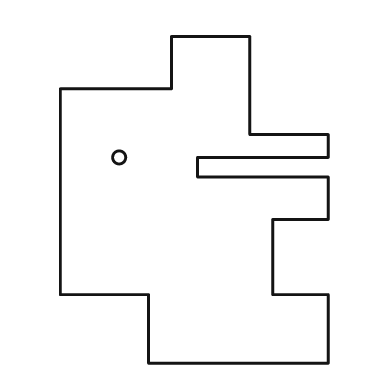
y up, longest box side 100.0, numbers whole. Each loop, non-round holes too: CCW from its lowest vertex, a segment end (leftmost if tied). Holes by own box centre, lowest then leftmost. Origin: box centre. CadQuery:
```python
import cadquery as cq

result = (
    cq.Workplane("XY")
    .moveTo(-14.0, -50.0)
    .lineTo(41.0, -50.0)
    .lineTo(41.0, -29.0)
    .lineTo(24.0, -29.0)
    .lineTo(24.0, -6.0)
    .lineTo(41.0, -6.0)
    .lineTo(41.0, 7.0)
    .lineTo(1.0, 7.0)
    .lineTo(1.0, 13.0)
    .lineTo(41.0, 13.0)
    .lineTo(41.0, 20.0)
    .lineTo(17.0, 20.0)
    .lineTo(17.0, 50.0)
    .lineTo(-7.0, 50.0)
    .lineTo(-7.0, 34.0)
    .lineTo(-41.0, 34.0)
    .lineTo(-41.0, -29.0)
    .lineTo(-14.0, -29.0)
    .close()
    .moveTo(-23.0, 13.0)
    .circle(2.0)
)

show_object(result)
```